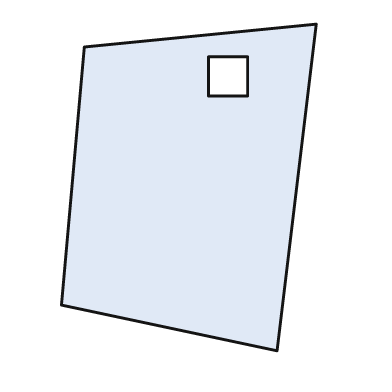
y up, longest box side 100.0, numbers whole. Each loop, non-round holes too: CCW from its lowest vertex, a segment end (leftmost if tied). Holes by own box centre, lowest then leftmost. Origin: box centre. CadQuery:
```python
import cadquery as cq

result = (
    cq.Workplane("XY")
    .moveTo(27.0, -50.0)
    .lineTo(39.0, 50.0)
    .lineTo(-32.0, 43.0)
    .lineTo(-39.0, -36.0)
    .close()
    .moveTo(6.0, 28.0)
    .lineTo(18.0, 28.0)
    .lineTo(18.0, 40.0)
    .lineTo(6.0, 40.0)
    .close()
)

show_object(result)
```